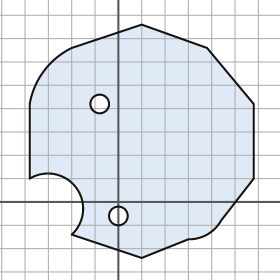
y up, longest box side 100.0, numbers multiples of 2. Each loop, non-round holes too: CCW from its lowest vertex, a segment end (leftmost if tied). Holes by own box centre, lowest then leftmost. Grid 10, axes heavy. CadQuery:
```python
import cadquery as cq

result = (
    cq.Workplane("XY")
    .moveTo(10.0, -24.0)
    .lineTo(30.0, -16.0)
    .threePointArc((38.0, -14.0), (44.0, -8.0))
    .lineTo(58.0, 10.0)
    .lineTo(58.0, 42.0)
    .lineTo(38.0, 66.0)
    .lineTo(10.0, 76.0)
    .lineTo(-20.0, 66.0)
    .threePointArc((-32.0, 56.0), (-38.0, 42.0))
    .lineTo(-38.0, 10.0)
    .threePointArc((-18.0, 6.0), (-20.0, -14.0))
    .close()
    .moveTo(0.0, -6.0)
    .circle(4.0)
    .moveTo(-8.0, 42.0)
    .circle(4.0)
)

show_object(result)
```